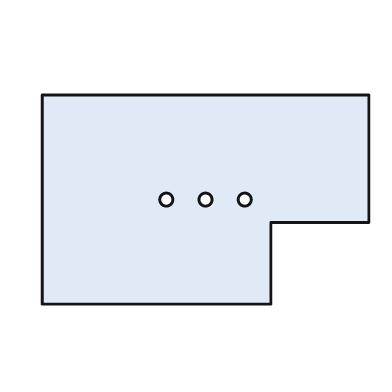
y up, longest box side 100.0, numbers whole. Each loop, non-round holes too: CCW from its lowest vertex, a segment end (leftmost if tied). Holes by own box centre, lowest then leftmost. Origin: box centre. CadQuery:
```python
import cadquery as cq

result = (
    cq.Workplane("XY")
    .moveTo(-50.0, -32.0)
    .lineTo(20.0, -32.0)
    .lineTo(20.0, -7.0)
    .lineTo(50.0, -7.0)
    .lineTo(50.0, 32.0)
    .lineTo(-50.0, 32.0)
    .close()
    .moveTo(-12.0, 0.0)
    .circle(2.0)
    .moveTo(0.0, 0.0)
    .circle(2.0)
    .moveTo(12.0, 0.0)
    .circle(2.0)
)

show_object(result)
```